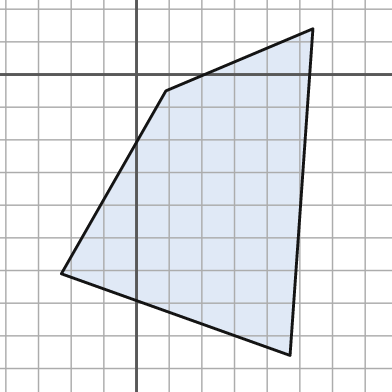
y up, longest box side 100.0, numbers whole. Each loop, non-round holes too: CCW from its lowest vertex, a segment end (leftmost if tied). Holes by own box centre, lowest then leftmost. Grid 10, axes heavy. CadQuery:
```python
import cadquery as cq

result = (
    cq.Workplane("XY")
    .moveTo(47.0, -86.0)
    .lineTo(54.0, 14.0)
    .lineTo(9.0, -5.0)
    .lineTo(-23.0, -61.0)
    .close()
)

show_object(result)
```